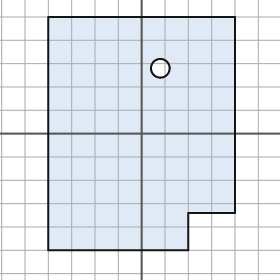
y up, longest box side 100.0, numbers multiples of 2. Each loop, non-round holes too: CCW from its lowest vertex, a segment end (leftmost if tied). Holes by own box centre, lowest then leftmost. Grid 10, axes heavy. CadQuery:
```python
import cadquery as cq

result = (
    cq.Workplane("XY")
    .moveTo(-40.0, -50.0)
    .lineTo(20.0, -50.0)
    .lineTo(20.0, -34.0)
    .lineTo(40.0, -34.0)
    .lineTo(40.0, 50.0)
    .lineTo(-40.0, 50.0)
    .close()
    .moveTo(8.0, 28.0)
    .circle(4.0)
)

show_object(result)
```